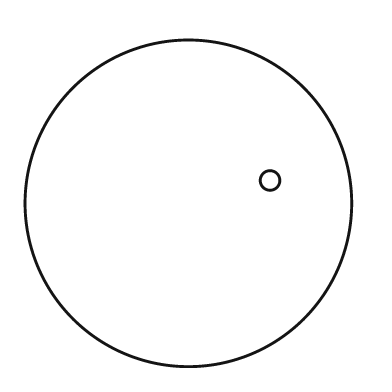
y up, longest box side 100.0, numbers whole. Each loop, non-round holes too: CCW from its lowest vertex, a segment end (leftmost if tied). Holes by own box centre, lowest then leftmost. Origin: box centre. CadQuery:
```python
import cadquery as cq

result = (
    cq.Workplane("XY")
    .moveTo(0.0, 0.0)
    .circle(50.0)
    .moveTo(25.0, 7.0)
    .circle(3.0)
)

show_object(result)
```